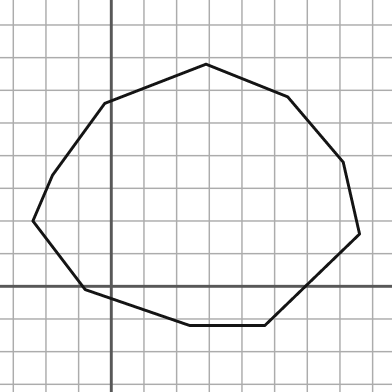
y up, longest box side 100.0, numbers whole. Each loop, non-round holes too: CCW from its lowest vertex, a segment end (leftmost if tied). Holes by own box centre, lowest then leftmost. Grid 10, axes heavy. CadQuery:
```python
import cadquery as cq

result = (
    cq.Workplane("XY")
    .moveTo(24.0, -12.0)
    .lineTo(47.0, -12.0)
    .lineTo(76.0, 16.0)
    .lineTo(71.0, 38.0)
    .lineTo(54.0, 58.0)
    .lineTo(29.0, 68.0)
    .lineTo(-2.0, 56.0)
    .lineTo(-18.0, 34.0)
    .lineTo(-24.0, 20.0)
    .lineTo(-8.0, -1.0)
    .close()
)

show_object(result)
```